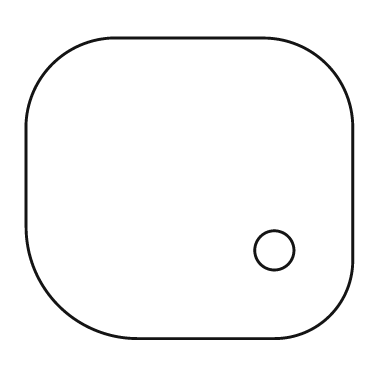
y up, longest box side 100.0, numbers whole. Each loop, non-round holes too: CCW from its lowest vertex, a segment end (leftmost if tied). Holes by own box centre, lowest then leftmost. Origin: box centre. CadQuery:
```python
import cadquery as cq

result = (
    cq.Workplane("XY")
    .moveTo(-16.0, -46.0)
    .lineTo(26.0, -46.0)
    .threePointArc((43.0, -39.0), (50.0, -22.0))
    .lineTo(50.0, 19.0)
    .threePointArc((42.0, 38.0), (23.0, 46.0))
    .lineTo(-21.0, 46.0)
    .threePointArc((-42.0, 38.0), (-50.0, 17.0))
    .lineTo(-50.0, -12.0)
    .threePointArc((-40.0, -36.0), (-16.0, -46.0))
    .close()
    .moveTo(26.0, -19.0)
    .circle(6.0)
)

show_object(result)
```